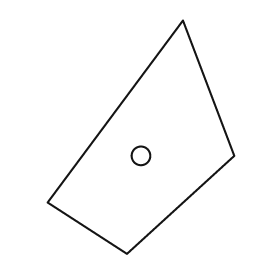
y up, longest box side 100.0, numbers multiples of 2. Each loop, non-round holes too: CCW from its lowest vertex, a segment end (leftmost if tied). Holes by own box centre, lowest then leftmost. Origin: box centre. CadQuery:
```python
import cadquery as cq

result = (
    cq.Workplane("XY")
    .moveTo(-6.0, -50.0)
    .lineTo(40.0, -8.0)
    .lineTo(18.0, 50.0)
    .lineTo(-40.0, -28.0)
    .close()
    .moveTo(0.0, -8.0)
    .circle(4.0)
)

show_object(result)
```